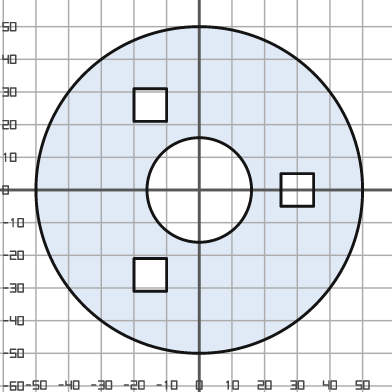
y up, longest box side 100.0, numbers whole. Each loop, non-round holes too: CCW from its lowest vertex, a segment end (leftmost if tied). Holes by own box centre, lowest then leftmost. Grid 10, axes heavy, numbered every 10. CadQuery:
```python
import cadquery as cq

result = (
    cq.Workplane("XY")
    .moveTo(0.0, 0.0)
    .circle(50.0)
    .moveTo(-20.0, -31.0)
    .lineTo(-10.0, -31.0)
    .lineTo(-10.0, -21.0)
    .lineTo(-20.0, -21.0)
    .close()
    .moveTo(0.0, 0.0)
    .circle(16.0)
    .moveTo(25.0, -5.0)
    .lineTo(35.0, -5.0)
    .lineTo(35.0, 5.0)
    .lineTo(25.0, 5.0)
    .close()
    .moveTo(-20.0, 21.0)
    .lineTo(-10.0, 21.0)
    .lineTo(-10.0, 31.0)
    .lineTo(-20.0, 31.0)
    .close()
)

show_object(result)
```